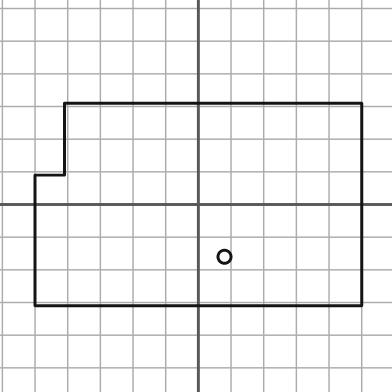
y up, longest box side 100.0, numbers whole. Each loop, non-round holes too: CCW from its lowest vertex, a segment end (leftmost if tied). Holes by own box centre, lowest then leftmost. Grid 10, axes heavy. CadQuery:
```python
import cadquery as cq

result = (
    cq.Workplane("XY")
    .moveTo(-50.0, -31.0)
    .lineTo(50.0, -31.0)
    .lineTo(50.0, 31.0)
    .lineTo(-41.0, 31.0)
    .lineTo(-41.0, 9.0)
    .lineTo(-50.0, 9.0)
    .close()
    .moveTo(8.0, -16.0)
    .circle(2.0)
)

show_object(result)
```